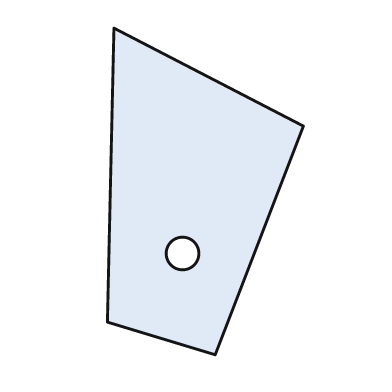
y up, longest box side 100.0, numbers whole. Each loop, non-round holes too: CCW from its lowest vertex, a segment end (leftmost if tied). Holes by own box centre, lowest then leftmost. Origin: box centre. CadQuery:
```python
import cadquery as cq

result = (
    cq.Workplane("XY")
    .moveTo(3.0, -50.0)
    .lineTo(30.0, 20.0)
    .lineTo(-28.0, 50.0)
    .lineTo(-30.0, -40.0)
    .close()
    .moveTo(-7.0, -19.0)
    .circle(5.0)
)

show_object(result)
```